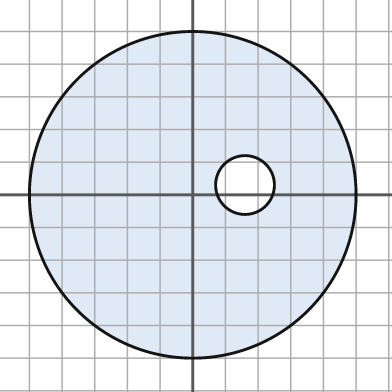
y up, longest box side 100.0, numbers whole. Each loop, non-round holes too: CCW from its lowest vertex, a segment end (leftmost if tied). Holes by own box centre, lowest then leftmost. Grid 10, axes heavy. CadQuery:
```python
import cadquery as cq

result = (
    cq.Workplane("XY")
    .moveTo(0.0, 0.0)
    .circle(50.0)
    .moveTo(16.0, 3.0)
    .circle(9.0)
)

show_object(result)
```